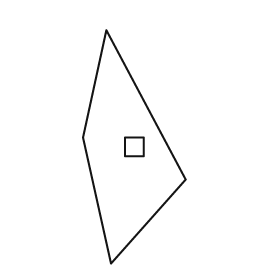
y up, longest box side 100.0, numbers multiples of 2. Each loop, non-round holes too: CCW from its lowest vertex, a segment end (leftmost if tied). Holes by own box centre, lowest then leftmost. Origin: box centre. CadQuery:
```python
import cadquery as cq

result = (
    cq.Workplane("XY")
    .moveTo(-10.0, -50.0)
    .lineTo(22.0, -14.0)
    .lineTo(-12.0, 50.0)
    .lineTo(-22.0, 4.0)
    .close()
    .moveTo(-4.0, -4.0)
    .lineTo(4.0, -4.0)
    .lineTo(4.0, 4.0)
    .lineTo(-4.0, 4.0)
    .close()
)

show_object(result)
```